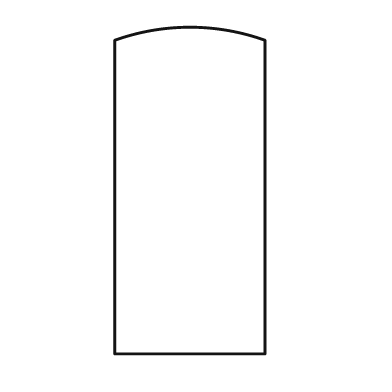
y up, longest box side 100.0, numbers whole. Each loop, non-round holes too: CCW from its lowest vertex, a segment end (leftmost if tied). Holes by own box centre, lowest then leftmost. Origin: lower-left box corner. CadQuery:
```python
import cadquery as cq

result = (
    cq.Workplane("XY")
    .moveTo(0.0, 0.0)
    .lineTo(46.0, 0.0)
    .lineTo(46.0, 96.0)
    .threePointArc((23.0, 100.0), (0.0, 96.0))
    .close()
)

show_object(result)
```